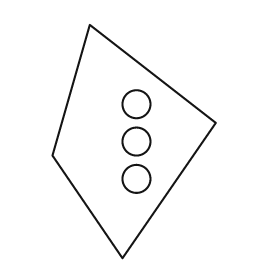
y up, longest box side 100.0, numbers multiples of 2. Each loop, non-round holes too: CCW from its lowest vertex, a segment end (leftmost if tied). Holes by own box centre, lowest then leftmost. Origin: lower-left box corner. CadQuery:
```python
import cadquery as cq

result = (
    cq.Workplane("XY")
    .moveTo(30.0, 0.0)
    .lineTo(70.0, 58.0)
    .lineTo(16.0, 100.0)
    .lineTo(0.0, 44.0)
    .close()
    .moveTo(36.0, 34.0)
    .circle(6.0)
    .moveTo(36.0, 50.0)
    .circle(6.0)
    .moveTo(36.0, 66.0)
    .circle(6.0)
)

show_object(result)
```